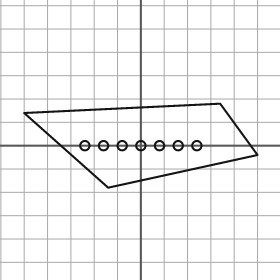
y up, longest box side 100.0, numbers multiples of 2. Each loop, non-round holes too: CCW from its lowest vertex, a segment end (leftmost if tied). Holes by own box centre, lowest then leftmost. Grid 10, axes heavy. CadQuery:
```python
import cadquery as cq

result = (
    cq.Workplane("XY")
    .moveTo(-14.0, -18.0)
    .lineTo(50.0, -4.0)
    .lineTo(34.0, 18.0)
    .lineTo(-50.0, 14.0)
    .close()
    .moveTo(-24.0, 0.0)
    .circle(2.0)
    .moveTo(-16.0, 0.0)
    .circle(2.0)
    .moveTo(-8.0, 0.0)
    .circle(2.0)
    .moveTo(0.0, 0.0)
    .circle(2.0)
    .moveTo(8.0, 0.0)
    .circle(2.0)
    .moveTo(16.0, 0.0)
    .circle(2.0)
    .moveTo(24.0, 0.0)
    .circle(2.0)
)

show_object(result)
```